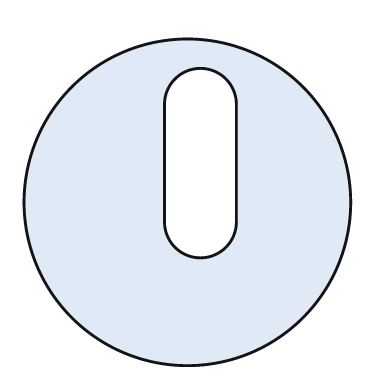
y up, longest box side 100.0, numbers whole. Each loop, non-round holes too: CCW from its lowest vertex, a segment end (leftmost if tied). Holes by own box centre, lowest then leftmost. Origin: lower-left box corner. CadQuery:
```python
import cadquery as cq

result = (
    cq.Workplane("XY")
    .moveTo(50.0, 50.0)
    .circle(50.0)
    .moveTo(43.0, 44.0)
    .threePointArc((54.0, 33.0), (65.0, 44.0))
    .lineTo(65.0, 80.0)
    .threePointArc((54.0, 91.0), (43.0, 80.0))
    .close()
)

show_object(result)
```